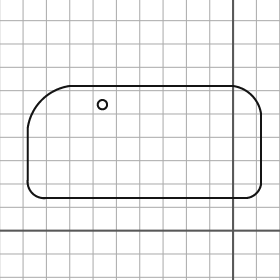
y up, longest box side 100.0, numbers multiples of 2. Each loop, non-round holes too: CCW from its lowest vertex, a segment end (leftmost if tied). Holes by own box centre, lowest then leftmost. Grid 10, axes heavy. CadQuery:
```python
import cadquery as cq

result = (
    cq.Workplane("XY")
    .moveTo(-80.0, 14.0)
    .lineTo(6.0, 14.0)
    .threePointArc((10.0, 16.0), (12.0, 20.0))
    .lineTo(12.0, 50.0)
    .threePointArc((8.0, 58.0), (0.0, 62.0))
    .lineTo(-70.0, 62.0)
    .threePointArc((-82.0, 56.0), (-88.0, 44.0))
    .lineTo(-88.0, 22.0)
    .threePointArc((-86.0, 16.0), (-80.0, 14.0))
    .close()
    .moveTo(-56.0, 54.0)
    .circle(2.0)
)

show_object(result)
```